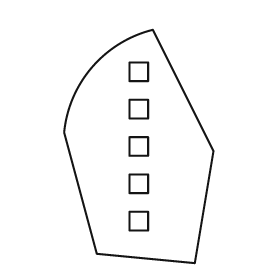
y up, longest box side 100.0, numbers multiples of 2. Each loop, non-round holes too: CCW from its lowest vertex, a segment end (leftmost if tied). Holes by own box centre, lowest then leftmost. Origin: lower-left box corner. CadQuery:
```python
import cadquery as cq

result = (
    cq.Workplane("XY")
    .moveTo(56.0, 0.0)
    .lineTo(64.0, 48.0)
    .lineTo(38.0, 100.0)
    .threePointArc((12.0, 84.0), (0.0, 56.0))
    .lineTo(14.0, 4.0)
    .close()
    .moveTo(28.0, 14.0)
    .lineTo(36.0, 14.0)
    .lineTo(36.0, 22.0)
    .lineTo(28.0, 22.0)
    .close()
    .moveTo(28.0, 30.0)
    .lineTo(36.0, 30.0)
    .lineTo(36.0, 38.0)
    .lineTo(28.0, 38.0)
    .close()
    .moveTo(28.0, 46.0)
    .lineTo(36.0, 46.0)
    .lineTo(36.0, 54.0)
    .lineTo(28.0, 54.0)
    .close()
    .moveTo(28.0, 62.0)
    .lineTo(36.0, 62.0)
    .lineTo(36.0, 70.0)
    .lineTo(28.0, 70.0)
    .close()
    .moveTo(28.0, 78.0)
    .lineTo(36.0, 78.0)
    .lineTo(36.0, 86.0)
    .lineTo(28.0, 86.0)
    .close()
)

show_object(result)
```